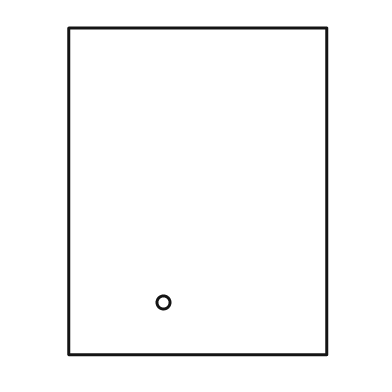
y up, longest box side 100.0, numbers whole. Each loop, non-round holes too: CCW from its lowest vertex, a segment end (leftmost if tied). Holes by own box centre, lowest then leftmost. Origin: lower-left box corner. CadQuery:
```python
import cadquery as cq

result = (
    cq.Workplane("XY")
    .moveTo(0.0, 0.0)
    .lineTo(79.0, 0.0)
    .lineTo(79.0, 100.0)
    .lineTo(0.0, 100.0)
    .close()
    .moveTo(29.0, 16.0)
    .circle(2.0)
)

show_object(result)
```